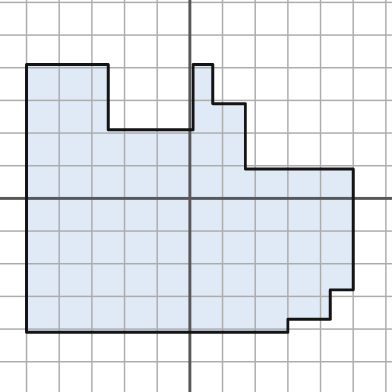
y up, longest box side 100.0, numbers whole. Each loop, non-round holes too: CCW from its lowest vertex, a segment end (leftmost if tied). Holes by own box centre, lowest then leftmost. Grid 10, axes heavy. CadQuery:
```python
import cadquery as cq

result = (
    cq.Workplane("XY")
    .moveTo(-50.0, -41.0)
    .lineTo(30.0, -41.0)
    .lineTo(30.0, -37.0)
    .lineTo(43.0, -37.0)
    .lineTo(43.0, -28.0)
    .lineTo(50.0, -28.0)
    .lineTo(50.0, 9.0)
    .lineTo(17.0, 9.0)
    .lineTo(17.0, 29.0)
    .lineTo(7.0, 29.0)
    .lineTo(7.0, 41.0)
    .lineTo(1.0, 41.0)
    .lineTo(1.0, 21.0)
    .lineTo(-25.0, 21.0)
    .lineTo(-25.0, 41.0)
    .lineTo(-50.0, 41.0)
    .close()
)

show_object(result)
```